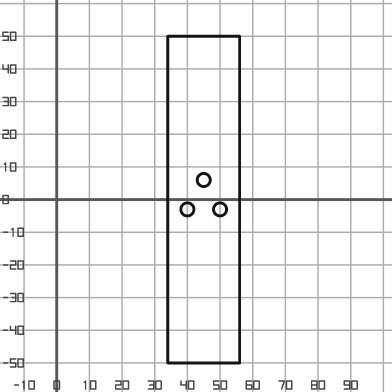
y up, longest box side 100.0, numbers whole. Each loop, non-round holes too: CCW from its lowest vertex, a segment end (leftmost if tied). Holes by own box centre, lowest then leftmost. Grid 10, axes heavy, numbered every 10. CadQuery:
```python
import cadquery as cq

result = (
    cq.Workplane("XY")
    .moveTo(34.0, -50.0)
    .lineTo(56.0, -50.0)
    .lineTo(56.0, 50.0)
    .lineTo(34.0, 50.0)
    .close()
    .moveTo(40.0, -3.0)
    .circle(2.0)
    .moveTo(50.0, -3.0)
    .circle(2.0)
    .moveTo(45.0, 6.0)
    .circle(2.0)
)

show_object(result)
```